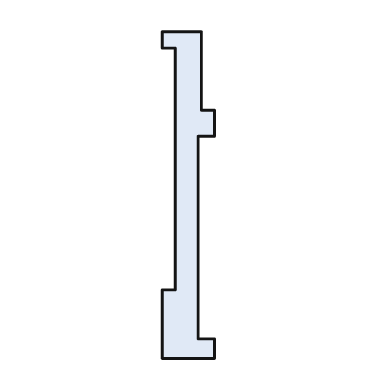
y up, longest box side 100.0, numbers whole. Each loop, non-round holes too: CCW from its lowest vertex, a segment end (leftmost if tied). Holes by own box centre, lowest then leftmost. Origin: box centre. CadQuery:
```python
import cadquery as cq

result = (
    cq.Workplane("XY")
    .moveTo(-8.0, -50.0)
    .lineTo(8.0, -50.0)
    .lineTo(8.0, -44.0)
    .lineTo(3.0, -44.0)
    .lineTo(3.0, 18.0)
    .lineTo(8.0, 18.0)
    .lineTo(8.0, 26.0)
    .lineTo(4.0, 26.0)
    .lineTo(4.0, 50.0)
    .lineTo(-8.0, 50.0)
    .lineTo(-8.0, 45.0)
    .lineTo(-4.0, 45.0)
    .lineTo(-4.0, -29.0)
    .lineTo(-8.0, -29.0)
    .close()
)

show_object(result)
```